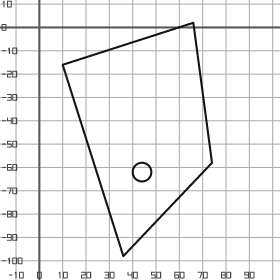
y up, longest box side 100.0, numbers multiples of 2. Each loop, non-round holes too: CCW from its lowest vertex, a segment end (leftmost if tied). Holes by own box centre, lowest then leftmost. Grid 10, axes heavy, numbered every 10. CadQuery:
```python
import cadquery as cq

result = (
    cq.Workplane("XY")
    .moveTo(36.0, -98.0)
    .lineTo(74.0, -58.0)
    .lineTo(66.0, 2.0)
    .lineTo(10.0, -16.0)
    .close()
    .moveTo(44.0, -62.0)
    .circle(4.0)
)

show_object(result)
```